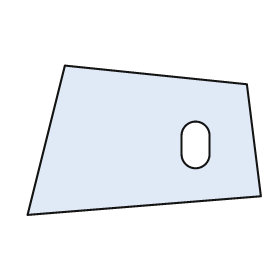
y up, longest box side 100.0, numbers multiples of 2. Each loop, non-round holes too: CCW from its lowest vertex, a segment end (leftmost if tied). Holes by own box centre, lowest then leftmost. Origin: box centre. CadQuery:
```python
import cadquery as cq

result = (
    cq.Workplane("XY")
    .moveTo(-50.0, -32.0)
    .lineTo(50.0, -24.0)
    .lineTo(44.0, 24.0)
    .lineTo(-34.0, 32.0)
    .close()
    .moveTo(16.0, -6.0)
    .threePointArc((22.0, -12.0), (28.0, -6.0))
    .lineTo(28.0, 2.0)
    .threePointArc((22.0, 8.0), (16.0, 2.0))
    .close()
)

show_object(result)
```